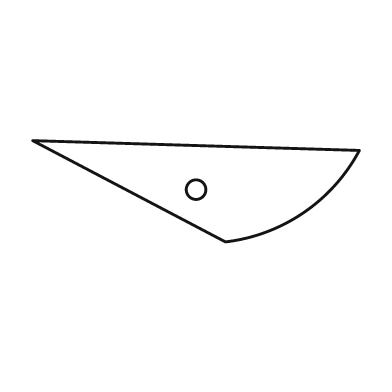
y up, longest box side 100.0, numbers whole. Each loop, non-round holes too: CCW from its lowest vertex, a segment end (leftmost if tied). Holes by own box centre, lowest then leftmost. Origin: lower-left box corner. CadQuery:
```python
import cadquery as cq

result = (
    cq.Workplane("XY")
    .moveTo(59.0, 0.0)
    .threePointArc((83.0, 9.0), (100.0, 28.0))
    .lineTo(0.0, 31.0)
    .close()
    .moveTo(50.0, 16.0)
    .circle(3.0)
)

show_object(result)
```